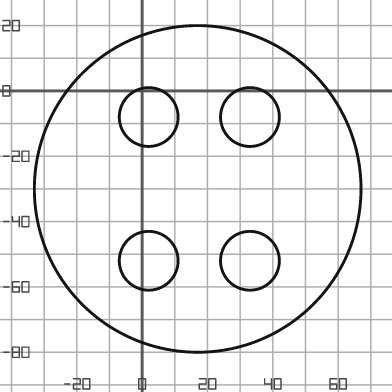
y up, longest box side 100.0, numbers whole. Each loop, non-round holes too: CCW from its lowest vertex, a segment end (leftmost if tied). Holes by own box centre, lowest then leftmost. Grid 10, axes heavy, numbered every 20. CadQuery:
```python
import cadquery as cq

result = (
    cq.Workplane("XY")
    .moveTo(17.0, -30.0)
    .circle(50.0)
    .moveTo(2.0, -52.0)
    .circle(9.0)
    .moveTo(33.0, -52.0)
    .circle(9.0)
    .moveTo(2.0, -8.0)
    .circle(9.0)
    .moveTo(33.0, -8.0)
    .circle(9.0)
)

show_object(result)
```